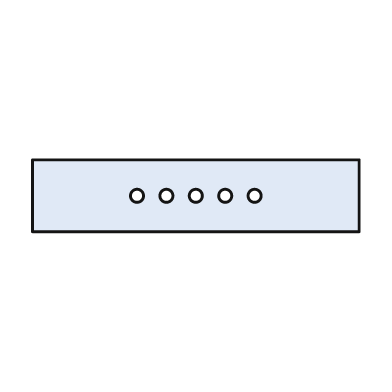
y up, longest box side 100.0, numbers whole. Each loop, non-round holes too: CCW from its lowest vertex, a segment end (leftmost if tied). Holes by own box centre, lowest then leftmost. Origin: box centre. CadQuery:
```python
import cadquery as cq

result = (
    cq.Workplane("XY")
    .moveTo(-50.0, -11.0)
    .lineTo(50.0, -11.0)
    .lineTo(50.0, 11.0)
    .lineTo(-50.0, 11.0)
    .close()
    .moveTo(-18.0, 0.0)
    .circle(2.0)
    .moveTo(-9.0, 0.0)
    .circle(2.0)
    .moveTo(0.0, 0.0)
    .circle(2.0)
    .moveTo(9.0, 0.0)
    .circle(2.0)
    .moveTo(18.0, 0.0)
    .circle(2.0)
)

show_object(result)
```